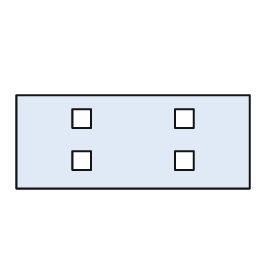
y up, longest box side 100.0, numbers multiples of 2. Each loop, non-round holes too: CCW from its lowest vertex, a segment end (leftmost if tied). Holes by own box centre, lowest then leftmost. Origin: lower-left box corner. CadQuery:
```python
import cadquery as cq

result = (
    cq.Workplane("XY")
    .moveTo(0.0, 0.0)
    .lineTo(100.0, 0.0)
    .lineTo(100.0, 40.0)
    .lineTo(0.0, 40.0)
    .close()
    .moveTo(24.0, 8.0)
    .lineTo(32.0, 8.0)
    .lineTo(32.0, 16.0)
    .lineTo(24.0, 16.0)
    .close()
    .moveTo(68.0, 8.0)
    .lineTo(76.0, 8.0)
    .lineTo(76.0, 16.0)
    .lineTo(68.0, 16.0)
    .close()
    .moveTo(24.0, 26.0)
    .lineTo(32.0, 26.0)
    .lineTo(32.0, 34.0)
    .lineTo(24.0, 34.0)
    .close()
    .moveTo(68.0, 26.0)
    .lineTo(76.0, 26.0)
    .lineTo(76.0, 34.0)
    .lineTo(68.0, 34.0)
    .close()
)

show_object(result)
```